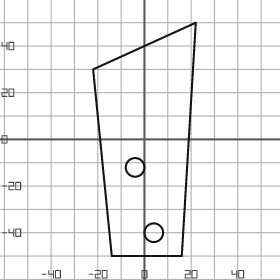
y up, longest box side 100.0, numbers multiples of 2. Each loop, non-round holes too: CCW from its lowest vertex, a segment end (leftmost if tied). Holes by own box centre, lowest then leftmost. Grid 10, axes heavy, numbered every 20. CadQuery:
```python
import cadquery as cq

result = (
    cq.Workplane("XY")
    .moveTo(-14.0, -50.0)
    .lineTo(16.0, -50.0)
    .lineTo(22.0, 50.0)
    .lineTo(-22.0, 30.0)
    .close()
    .moveTo(4.0, -40.0)
    .circle(4.0)
    .moveTo(-4.0, -12.0)
    .circle(4.0)
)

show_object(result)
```